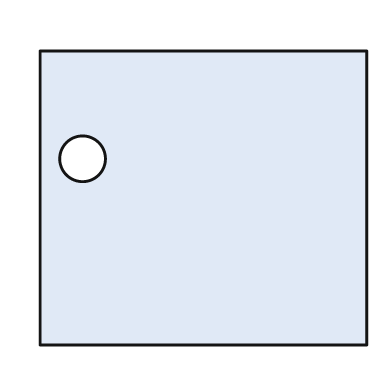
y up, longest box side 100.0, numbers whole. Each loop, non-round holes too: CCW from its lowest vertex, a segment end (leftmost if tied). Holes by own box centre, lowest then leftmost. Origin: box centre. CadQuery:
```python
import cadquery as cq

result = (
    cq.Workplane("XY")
    .moveTo(-50.0, -45.0)
    .lineTo(50.0, -45.0)
    .lineTo(50.0, 45.0)
    .lineTo(-50.0, 45.0)
    .close()
    .moveTo(-37.0, 12.0)
    .circle(7.0)
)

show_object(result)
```